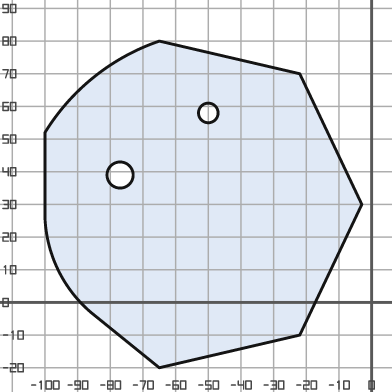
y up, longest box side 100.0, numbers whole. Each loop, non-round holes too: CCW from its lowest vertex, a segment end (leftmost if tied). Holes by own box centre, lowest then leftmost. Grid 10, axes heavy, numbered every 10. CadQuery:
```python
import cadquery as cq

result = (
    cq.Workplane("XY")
    .moveTo(-65.0, -20.0)
    .lineTo(-22.0, -10.0)
    .lineTo(-3.0, 30.0)
    .lineTo(-22.0, 70.0)
    .lineTo(-65.0, 80.0)
    .threePointArc((-85.0, 69.0), (-100.0, 52.0))
    .lineTo(-100.0, 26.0)
    .threePointArc((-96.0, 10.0), (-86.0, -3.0))
    .close()
    .moveTo(-77.0, 39.0)
    .circle(4.0)
    .moveTo(-50.0, 58.0)
    .circle(3.0)
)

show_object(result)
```